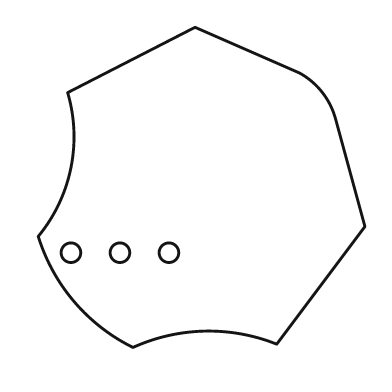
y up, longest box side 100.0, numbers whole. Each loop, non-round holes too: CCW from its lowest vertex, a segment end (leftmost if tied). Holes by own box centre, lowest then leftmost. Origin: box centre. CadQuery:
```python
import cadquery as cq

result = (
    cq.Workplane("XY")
    .moveTo(-21.0, -49.0)
    .threePointArc((1.0, -44.0), (23.0, -48.0))
    .lineTo(50.0, -12.0)
    .lineTo(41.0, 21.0)
    .threePointArc((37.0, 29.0), (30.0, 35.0))
    .lineTo(-2.0, 49.0)
    .lineTo(-41.0, 29.0)
    .threePointArc((-40.0, 6.0), (-50.0, -15.0))
    .threePointArc((-39.0, -35.0), (-21.0, -49.0))
    .close()
    .moveTo(-40.0, -20.0)
    .circle(3.0)
    .moveTo(-25.0, -20.0)
    .circle(3.0)
    .moveTo(-10.0, -20.0)
    .circle(3.0)
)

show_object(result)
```